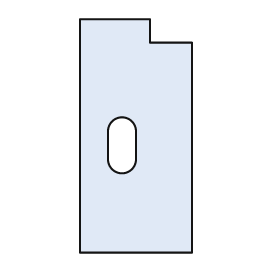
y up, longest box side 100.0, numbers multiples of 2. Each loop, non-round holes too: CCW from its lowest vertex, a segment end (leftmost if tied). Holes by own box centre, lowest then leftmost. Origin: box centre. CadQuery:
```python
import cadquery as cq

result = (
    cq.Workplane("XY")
    .moveTo(-24.0, -50.0)
    .lineTo(24.0, -50.0)
    .lineTo(24.0, 40.0)
    .lineTo(6.0, 40.0)
    .lineTo(6.0, 50.0)
    .lineTo(-24.0, 50.0)
    .close()
    .moveTo(-12.0, -10.0)
    .threePointArc((-6.0, -16.0), (0.0, -10.0))
    .lineTo(0.0, 2.0)
    .threePointArc((-6.0, 8.0), (-12.0, 2.0))
    .close()
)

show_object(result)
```